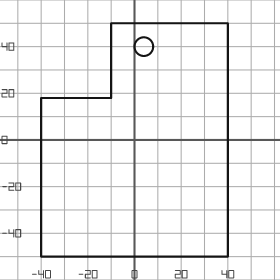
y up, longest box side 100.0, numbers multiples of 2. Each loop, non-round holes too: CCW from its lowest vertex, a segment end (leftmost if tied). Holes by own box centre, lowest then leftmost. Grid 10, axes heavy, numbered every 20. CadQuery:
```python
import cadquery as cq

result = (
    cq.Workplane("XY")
    .moveTo(-40.0, -50.0)
    .lineTo(40.0, -50.0)
    .lineTo(40.0, 50.0)
    .lineTo(-10.0, 50.0)
    .lineTo(-10.0, 18.0)
    .lineTo(-40.0, 18.0)
    .close()
    .moveTo(4.0, 40.0)
    .circle(4.0)
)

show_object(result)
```